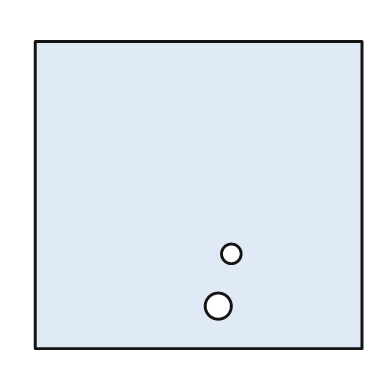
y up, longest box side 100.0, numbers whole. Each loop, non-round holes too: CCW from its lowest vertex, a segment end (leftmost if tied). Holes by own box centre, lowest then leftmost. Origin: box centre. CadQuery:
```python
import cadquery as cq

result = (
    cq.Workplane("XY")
    .moveTo(-50.0, -47.0)
    .lineTo(50.0, -47.0)
    .lineTo(50.0, 47.0)
    .lineTo(-50.0, 47.0)
    .close()
    .moveTo(6.0, -34.0)
    .circle(4.0)
    .moveTo(10.0, -18.0)
    .circle(3.0)
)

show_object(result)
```